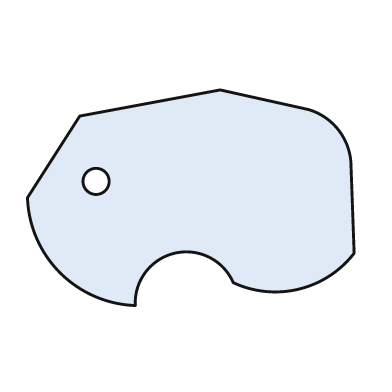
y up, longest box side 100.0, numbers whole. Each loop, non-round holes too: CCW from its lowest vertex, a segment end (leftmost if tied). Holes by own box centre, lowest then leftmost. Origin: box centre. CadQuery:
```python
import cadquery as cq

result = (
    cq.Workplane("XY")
    .moveTo(-17.0, -33.0)
    .threePointArc((-5.0, -17.0), (13.0, -26.0))
    .threePointArc((33.0, -28.0), (50.0, -17.0))
    .lineTo(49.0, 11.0)
    .threePointArc((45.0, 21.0), (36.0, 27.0))
    .lineTo(9.0, 33.0)
    .lineTo(-34.0, 25.0)
    .lineTo(-50.0, 0.0)
    .threePointArc((-40.0, -23.0), (-17.0, -33.0))
    .close()
    .moveTo(-29.0, 5.0)
    .circle(4.0)
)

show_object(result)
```